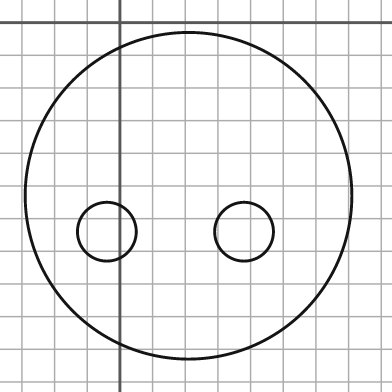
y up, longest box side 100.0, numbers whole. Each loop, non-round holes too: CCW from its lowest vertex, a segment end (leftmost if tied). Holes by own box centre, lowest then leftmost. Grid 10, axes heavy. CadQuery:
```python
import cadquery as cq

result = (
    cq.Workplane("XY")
    .moveTo(21.0, -53.0)
    .circle(50.0)
    .moveTo(-4.0, -64.0)
    .circle(9.0)
    .moveTo(38.0, -64.0)
    .circle(9.0)
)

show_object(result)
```